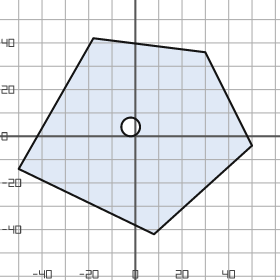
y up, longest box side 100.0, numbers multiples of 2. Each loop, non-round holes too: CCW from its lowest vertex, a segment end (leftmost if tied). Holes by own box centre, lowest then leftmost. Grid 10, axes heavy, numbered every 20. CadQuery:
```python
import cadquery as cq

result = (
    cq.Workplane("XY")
    .moveTo(8.0, -42.0)
    .lineTo(50.0, -4.0)
    .lineTo(30.0, 36.0)
    .lineTo(-18.0, 42.0)
    .lineTo(-50.0, -14.0)
    .close()
    .moveTo(-2.0, 4.0)
    .circle(4.0)
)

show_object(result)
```